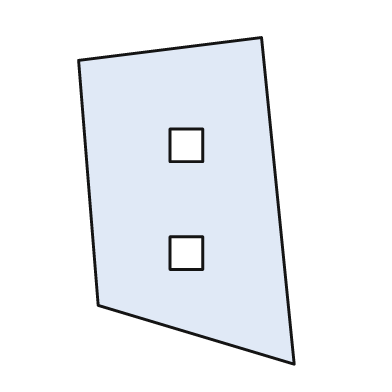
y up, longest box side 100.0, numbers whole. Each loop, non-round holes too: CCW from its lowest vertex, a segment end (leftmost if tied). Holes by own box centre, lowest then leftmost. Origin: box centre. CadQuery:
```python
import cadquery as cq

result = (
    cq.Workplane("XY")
    .moveTo(33.0, -50.0)
    .lineTo(23.0, 50.0)
    .lineTo(-33.0, 43.0)
    .lineTo(-27.0, -32.0)
    .close()
    .moveTo(-5.0, -21.0)
    .lineTo(5.0, -21.0)
    .lineTo(5.0, -11.0)
    .lineTo(-5.0, -11.0)
    .close()
    .moveTo(-5.0, 12.0)
    .lineTo(5.0, 12.0)
    .lineTo(5.0, 22.0)
    .lineTo(-5.0, 22.0)
    .close()
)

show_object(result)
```